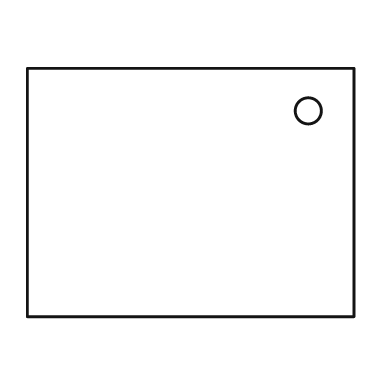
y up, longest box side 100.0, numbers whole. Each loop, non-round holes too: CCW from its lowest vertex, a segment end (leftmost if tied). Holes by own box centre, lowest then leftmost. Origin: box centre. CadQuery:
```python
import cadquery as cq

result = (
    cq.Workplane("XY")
    .moveTo(-50.0, -38.0)
    .lineTo(50.0, -38.0)
    .lineTo(50.0, 38.0)
    .lineTo(-50.0, 38.0)
    .close()
    .moveTo(36.0, 25.0)
    .circle(4.0)
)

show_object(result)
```